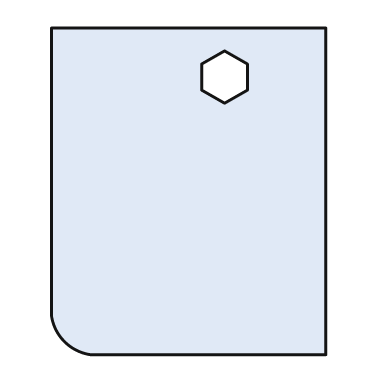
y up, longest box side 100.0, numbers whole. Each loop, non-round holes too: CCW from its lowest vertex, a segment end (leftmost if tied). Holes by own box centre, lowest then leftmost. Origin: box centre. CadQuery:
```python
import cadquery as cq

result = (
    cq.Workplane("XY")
    .moveTo(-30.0, -50.0)
    .lineTo(42.0, -50.0)
    .lineTo(42.0, 50.0)
    .lineTo(-42.0, 50.0)
    .lineTo(-42.0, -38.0)
    .threePointArc((-38.0, -46.0), (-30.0, -50.0))
    .close()
    .moveTo(11.0, 27.0)
    .lineTo(18.0, 31.0)
    .lineTo(18.0, 39.0)
    .lineTo(11.0, 43.0)
    .lineTo(4.0, 39.0)
    .lineTo(4.0, 31.0)
    .close()
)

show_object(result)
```